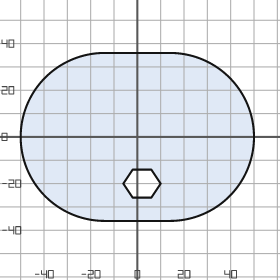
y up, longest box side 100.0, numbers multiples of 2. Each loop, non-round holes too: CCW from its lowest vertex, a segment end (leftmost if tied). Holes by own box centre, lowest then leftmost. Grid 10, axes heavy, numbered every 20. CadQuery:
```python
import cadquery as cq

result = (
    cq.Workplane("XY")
    .moveTo(-14.0, -36.0)
    .lineTo(14.0, -36.0)
    .threePointArc((50.0, 0.0), (14.0, 36.0))
    .lineTo(-14.0, 36.0)
    .threePointArc((-50.0, 0.0), (-14.0, -36.0))
    .close()
    .moveTo(-2.0, -26.0)
    .lineTo(6.0, -26.0)
    .lineTo(10.0, -20.0)
    .lineTo(6.0, -14.0)
    .lineTo(-2.0, -14.0)
    .lineTo(-6.0, -20.0)
    .close()
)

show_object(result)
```